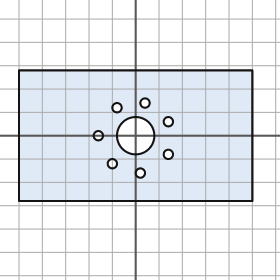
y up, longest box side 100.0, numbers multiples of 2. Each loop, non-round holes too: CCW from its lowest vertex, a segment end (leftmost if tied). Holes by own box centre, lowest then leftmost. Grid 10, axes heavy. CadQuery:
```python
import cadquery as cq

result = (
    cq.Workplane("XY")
    .moveTo(-50.0, -28.0)
    .lineTo(50.0, -28.0)
    .lineTo(50.0, 28.0)
    .lineTo(-50.0, 28.0)
    .close()
    .moveTo(2.0, -16.0)
    .circle(2.0)
    .moveTo(-10.0, -12.0)
    .circle(2.0)
    .moveTo(14.0, -8.0)
    .circle(2.0)
    .moveTo(-16.0, 0.0)
    .circle(2.0)
    .moveTo(0.0, 0.0)
    .circle(8.0)
    .moveTo(14.0, 6.0)
    .circle(2.0)
    .moveTo(-8.0, 12.0)
    .circle(2.0)
    .moveTo(4.0, 14.0)
    .circle(2.0)
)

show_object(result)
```